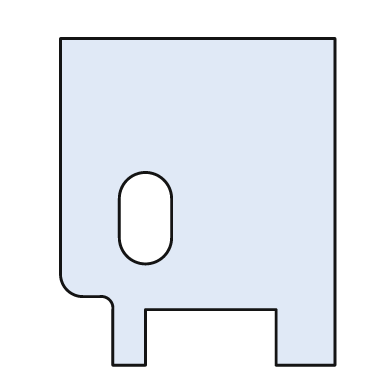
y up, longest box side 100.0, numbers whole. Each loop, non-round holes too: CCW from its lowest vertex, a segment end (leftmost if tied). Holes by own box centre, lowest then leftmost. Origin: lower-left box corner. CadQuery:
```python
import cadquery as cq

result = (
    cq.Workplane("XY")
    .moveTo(16.0, 0.0)
    .lineTo(26.0, 0.0)
    .lineTo(26.0, 17.0)
    .lineTo(66.0, 17.0)
    .lineTo(66.0, 0.0)
    .lineTo(84.0, 0.0)
    .lineTo(84.0, 100.0)
    .lineTo(0.0, 100.0)
    .lineTo(0.0, 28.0)
    .threePointArc((2.0, 23.0), (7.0, 21.0))
    .lineTo(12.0, 21.0)
    .threePointArc((15.0, 20.0), (16.0, 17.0))
    .close()
    .moveTo(18.0, 39.0)
    .threePointArc((26.0, 31.0), (34.0, 39.0))
    .lineTo(34.0, 51.0)
    .threePointArc((26.0, 59.0), (18.0, 51.0))
    .close()
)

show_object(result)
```